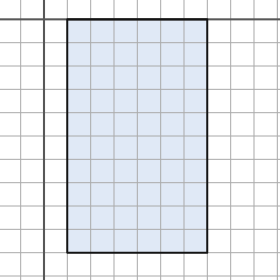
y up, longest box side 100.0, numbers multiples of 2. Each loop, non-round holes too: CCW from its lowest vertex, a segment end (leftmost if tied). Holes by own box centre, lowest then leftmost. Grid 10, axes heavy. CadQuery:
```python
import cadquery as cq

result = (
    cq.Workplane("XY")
    .moveTo(10.0, -100.0)
    .lineTo(70.0, -100.0)
    .lineTo(70.0, 0.0)
    .lineTo(10.0, 0.0)
    .close()
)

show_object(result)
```